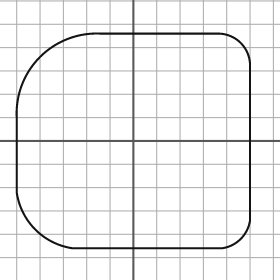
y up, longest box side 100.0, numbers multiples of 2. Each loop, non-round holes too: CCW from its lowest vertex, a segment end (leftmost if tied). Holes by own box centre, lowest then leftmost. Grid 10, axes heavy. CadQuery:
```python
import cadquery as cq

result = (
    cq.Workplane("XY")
    .moveTo(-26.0, -46.0)
    .lineTo(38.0, -46.0)
    .threePointArc((46.0, -42.0), (50.0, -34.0))
    .lineTo(50.0, 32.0)
    .threePointArc((46.0, 42.0), (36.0, 46.0))
    .lineTo(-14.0, 46.0)
    .threePointArc((-40.0, 36.0), (-50.0, 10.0))
    .lineTo(-50.0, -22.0)
    .threePointArc((-42.0, -38.0), (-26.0, -46.0))
    .close()
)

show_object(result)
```